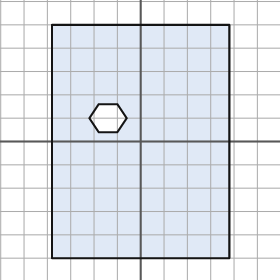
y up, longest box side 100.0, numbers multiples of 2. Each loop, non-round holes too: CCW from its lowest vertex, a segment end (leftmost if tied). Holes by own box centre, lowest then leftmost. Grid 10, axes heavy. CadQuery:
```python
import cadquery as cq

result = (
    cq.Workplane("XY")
    .moveTo(-38.0, -50.0)
    .lineTo(38.0, -50.0)
    .lineTo(38.0, 50.0)
    .lineTo(-38.0, 50.0)
    .close()
    .moveTo(-18.0, 4.0)
    .lineTo(-10.0, 4.0)
    .lineTo(-6.0, 10.0)
    .lineTo(-10.0, 16.0)
    .lineTo(-18.0, 16.0)
    .lineTo(-22.0, 10.0)
    .close()
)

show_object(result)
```